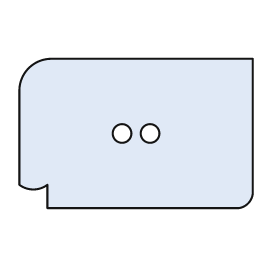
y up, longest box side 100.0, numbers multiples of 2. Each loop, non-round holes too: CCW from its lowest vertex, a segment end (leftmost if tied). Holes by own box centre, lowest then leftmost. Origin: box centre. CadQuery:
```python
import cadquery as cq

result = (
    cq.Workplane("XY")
    .moveTo(-38.0, -32.0)
    .lineTo(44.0, -32.0)
    .threePointArc((48.0, -30.0), (50.0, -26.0))
    .lineTo(50.0, 32.0)
    .lineTo(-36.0, 32.0)
    .threePointArc((-46.0, 28.0), (-50.0, 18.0))
    .lineTo(-50.0, -22.0)
    .threePointArc((-44.0, -24.0), (-38.0, -22.0))
    .close()
    .moveTo(-6.0, 0.0)
    .circle(4.0)
    .moveTo(6.0, 0.0)
    .circle(4.0)
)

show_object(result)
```